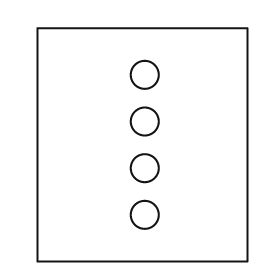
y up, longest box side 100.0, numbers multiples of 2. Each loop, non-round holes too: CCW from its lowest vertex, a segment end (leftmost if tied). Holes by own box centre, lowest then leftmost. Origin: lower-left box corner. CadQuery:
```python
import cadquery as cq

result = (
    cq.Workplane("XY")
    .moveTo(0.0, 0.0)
    .lineTo(90.0, 0.0)
    .lineTo(90.0, 100.0)
    .lineTo(0.0, 100.0)
    .close()
    .moveTo(46.0, 20.0)
    .circle(6.0)
    .moveTo(46.0, 40.0)
    .circle(6.0)
    .moveTo(46.0, 60.0)
    .circle(6.0)
    .moveTo(46.0, 80.0)
    .circle(6.0)
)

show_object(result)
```